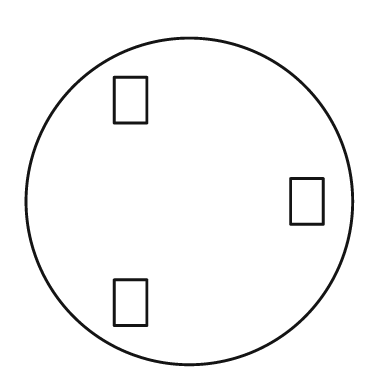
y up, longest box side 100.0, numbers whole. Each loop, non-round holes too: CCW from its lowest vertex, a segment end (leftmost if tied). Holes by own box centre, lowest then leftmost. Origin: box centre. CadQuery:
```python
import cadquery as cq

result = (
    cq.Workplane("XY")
    .moveTo(0.0, 0.0)
    .circle(50.0)
    .moveTo(-23.0, -38.0)
    .lineTo(-13.0, -38.0)
    .lineTo(-13.0, -24.0)
    .lineTo(-23.0, -24.0)
    .close()
    .moveTo(31.0, -7.0)
    .lineTo(41.0, -7.0)
    .lineTo(41.0, 7.0)
    .lineTo(31.0, 7.0)
    .close()
    .moveTo(-23.0, 24.0)
    .lineTo(-13.0, 24.0)
    .lineTo(-13.0, 38.0)
    .lineTo(-23.0, 38.0)
    .close()
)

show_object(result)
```